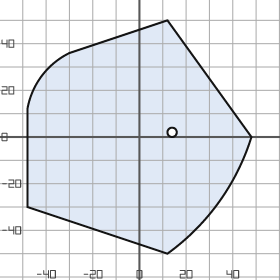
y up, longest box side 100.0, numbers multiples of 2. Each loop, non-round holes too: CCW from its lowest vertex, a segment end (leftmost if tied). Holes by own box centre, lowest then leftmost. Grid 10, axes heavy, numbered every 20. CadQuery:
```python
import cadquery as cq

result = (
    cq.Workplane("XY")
    .moveTo(12.0, -50.0)
    .threePointArc((34.0, -28.0), (48.0, 0.0))
    .lineTo(12.0, 50.0)
    .lineTo(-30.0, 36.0)
    .threePointArc((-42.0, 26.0), (-48.0, 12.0))
    .lineTo(-48.0, -30.0)
    .close()
    .moveTo(14.0, 2.0)
    .circle(2.0)
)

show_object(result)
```